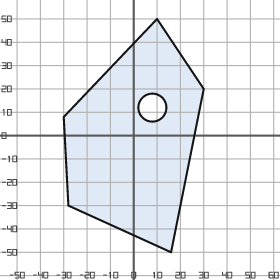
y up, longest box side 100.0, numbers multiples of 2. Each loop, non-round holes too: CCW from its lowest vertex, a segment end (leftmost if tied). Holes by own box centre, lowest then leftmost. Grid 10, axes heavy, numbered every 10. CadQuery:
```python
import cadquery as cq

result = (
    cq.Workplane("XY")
    .moveTo(16.0, -50.0)
    .lineTo(30.0, 20.0)
    .lineTo(10.0, 50.0)
    .lineTo(-30.0, 8.0)
    .lineTo(-28.0, -30.0)
    .close()
    .moveTo(8.0, 12.0)
    .circle(6.0)
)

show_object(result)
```